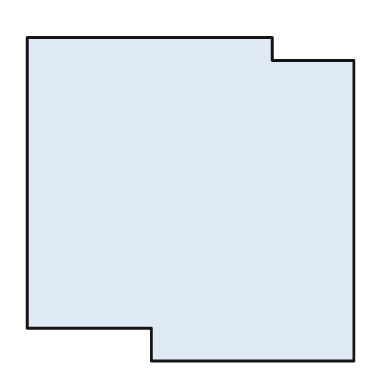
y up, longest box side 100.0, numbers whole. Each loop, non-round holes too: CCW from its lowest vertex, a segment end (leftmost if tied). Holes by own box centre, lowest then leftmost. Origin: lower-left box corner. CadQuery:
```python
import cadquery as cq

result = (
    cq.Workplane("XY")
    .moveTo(38.0, 0.0)
    .lineTo(100.0, 0.0)
    .lineTo(100.0, 92.0)
    .lineTo(75.0, 92.0)
    .lineTo(75.0, 99.0)
    .lineTo(0.0, 99.0)
    .lineTo(0.0, 10.0)
    .lineTo(38.0, 10.0)
    .close()
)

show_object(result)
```